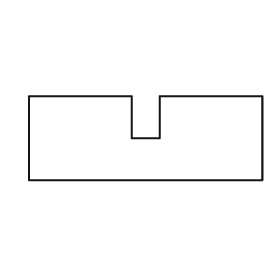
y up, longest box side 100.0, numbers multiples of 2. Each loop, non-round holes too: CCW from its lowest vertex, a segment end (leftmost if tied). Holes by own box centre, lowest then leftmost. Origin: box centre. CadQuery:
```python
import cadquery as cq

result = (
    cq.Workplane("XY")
    .moveTo(-50.0, -18.0)
    .lineTo(50.0, -18.0)
    .lineTo(50.0, 18.0)
    .lineTo(6.0, 18.0)
    .lineTo(6.0, 0.0)
    .lineTo(-6.0, 0.0)
    .lineTo(-6.0, 18.0)
    .lineTo(-50.0, 18.0)
    .close()
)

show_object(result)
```